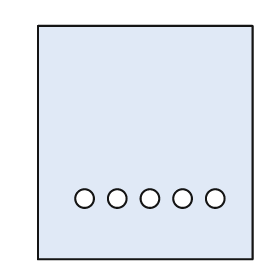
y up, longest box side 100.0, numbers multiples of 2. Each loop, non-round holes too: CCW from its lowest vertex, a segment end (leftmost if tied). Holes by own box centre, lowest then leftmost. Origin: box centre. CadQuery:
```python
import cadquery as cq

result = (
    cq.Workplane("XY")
    .moveTo(-46.0, -50.0)
    .lineTo(46.0, -50.0)
    .lineTo(46.0, 50.0)
    .lineTo(-46.0, 50.0)
    .close()
    .moveTo(-26.0, -24.0)
    .circle(4.0)
    .moveTo(-12.0, -24.0)
    .circle(4.0)
    .moveTo(2.0, -24.0)
    .circle(4.0)
    .moveTo(16.0, -24.0)
    .circle(4.0)
    .moveTo(30.0, -24.0)
    .circle(4.0)
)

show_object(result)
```